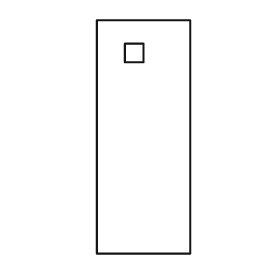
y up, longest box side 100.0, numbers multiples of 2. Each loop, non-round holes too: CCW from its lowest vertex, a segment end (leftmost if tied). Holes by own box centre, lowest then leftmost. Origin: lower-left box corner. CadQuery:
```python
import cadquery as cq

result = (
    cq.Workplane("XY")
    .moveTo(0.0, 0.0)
    .lineTo(40.0, 0.0)
    .lineTo(40.0, 100.0)
    .lineTo(0.0, 100.0)
    .close()
    .moveTo(12.0, 82.0)
    .lineTo(20.0, 82.0)
    .lineTo(20.0, 90.0)
    .lineTo(12.0, 90.0)
    .close()
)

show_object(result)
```